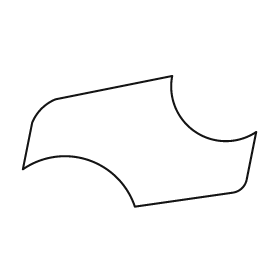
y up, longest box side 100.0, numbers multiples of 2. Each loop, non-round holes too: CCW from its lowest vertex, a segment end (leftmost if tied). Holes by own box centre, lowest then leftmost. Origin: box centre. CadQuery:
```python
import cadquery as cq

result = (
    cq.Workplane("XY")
    .moveTo(-2.0, -28.0)
    .lineTo(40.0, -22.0)
    .threePointArc((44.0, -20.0), (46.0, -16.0))
    .lineTo(50.0, 4.0)
    .threePointArc((24.0, 4.0), (14.0, 28.0))
    .lineTo(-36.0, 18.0)
    .threePointArc((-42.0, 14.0), (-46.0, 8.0))
    .lineTo(-50.0, -12.0)
    .threePointArc((-22.0, -8.0), (-2.0, -28.0))
    .close()
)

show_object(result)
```